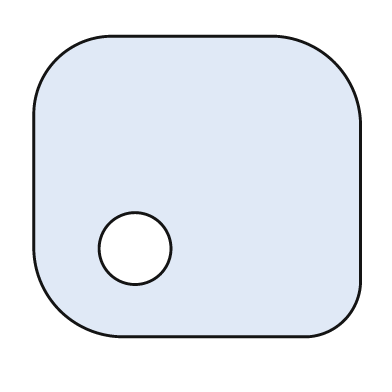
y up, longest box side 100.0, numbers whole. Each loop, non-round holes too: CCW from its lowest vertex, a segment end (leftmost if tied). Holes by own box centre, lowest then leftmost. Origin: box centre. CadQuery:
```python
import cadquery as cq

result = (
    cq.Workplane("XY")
    .moveTo(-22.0, -46.0)
    .lineTo(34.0, -46.0)
    .threePointArc((45.0, -41.0), (50.0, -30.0))
    .lineTo(50.0, 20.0)
    .threePointArc((42.0, 38.0), (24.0, 46.0))
    .lineTo(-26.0, 46.0)
    .threePointArc((-43.0, 39.0), (-50.0, 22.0))
    .lineTo(-50.0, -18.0)
    .threePointArc((-42.0, -38.0), (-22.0, -46.0))
    .close()
    .moveTo(-19.0, -19.0)
    .circle(11.0)
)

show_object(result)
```